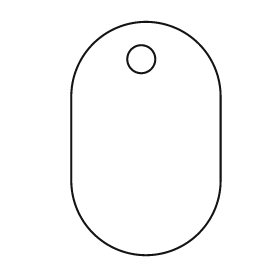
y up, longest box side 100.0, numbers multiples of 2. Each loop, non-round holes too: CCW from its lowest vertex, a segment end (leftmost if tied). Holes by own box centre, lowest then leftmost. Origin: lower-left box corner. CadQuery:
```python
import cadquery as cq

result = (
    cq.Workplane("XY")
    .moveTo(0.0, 32.0)
    .threePointArc((32.0, 0.0), (64.0, 32.0))
    .lineTo(64.0, 68.0)
    .threePointArc((32.0, 100.0), (0.0, 68.0))
    .close()
    .moveTo(30.0, 84.0)
    .circle(6.0)
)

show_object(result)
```